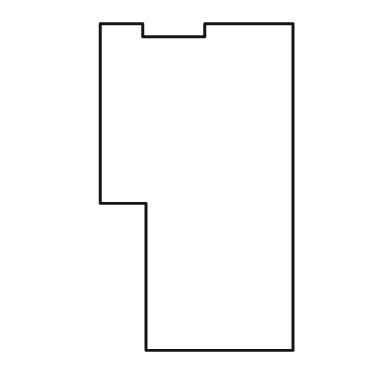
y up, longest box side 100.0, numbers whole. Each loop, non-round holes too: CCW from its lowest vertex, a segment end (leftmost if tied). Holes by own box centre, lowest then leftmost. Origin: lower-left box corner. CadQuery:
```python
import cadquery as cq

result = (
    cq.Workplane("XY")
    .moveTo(14.0, 0.0)
    .lineTo(59.0, 0.0)
    .lineTo(59.0, 100.0)
    .lineTo(32.0, 100.0)
    .lineTo(32.0, 96.0)
    .lineTo(13.0, 96.0)
    .lineTo(13.0, 100.0)
    .lineTo(0.0, 100.0)
    .lineTo(0.0, 45.0)
    .lineTo(14.0, 45.0)
    .close()
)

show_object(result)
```